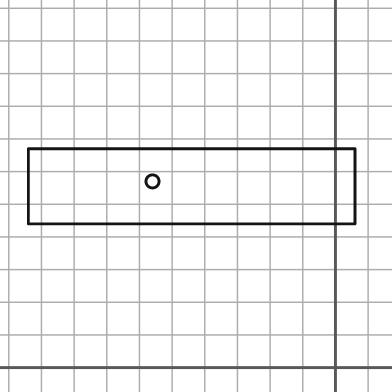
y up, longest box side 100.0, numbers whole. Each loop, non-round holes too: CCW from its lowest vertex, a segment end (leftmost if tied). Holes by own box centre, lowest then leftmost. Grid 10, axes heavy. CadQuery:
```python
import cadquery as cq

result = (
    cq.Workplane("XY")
    .moveTo(-94.0, 44.0)
    .lineTo(6.0, 44.0)
    .lineTo(6.0, 67.0)
    .lineTo(-94.0, 67.0)
    .close()
    .moveTo(-56.0, 57.0)
    .circle(2.0)
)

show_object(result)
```